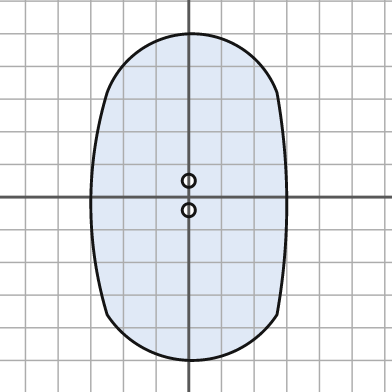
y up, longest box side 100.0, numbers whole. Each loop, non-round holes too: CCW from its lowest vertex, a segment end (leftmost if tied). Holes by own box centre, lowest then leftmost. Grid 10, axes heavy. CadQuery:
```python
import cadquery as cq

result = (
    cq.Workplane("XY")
    .moveTo(-25.0, -36.0)
    .threePointArc((1.0, -50.0), (27.0, -36.0))
    .threePointArc((30.0, -2.0), (27.0, 32.0))
    .threePointArc((1.0, 50.0), (-25.0, 32.0))
    .threePointArc((-30.0, -2.0), (-25.0, -36.0))
    .close()
    .moveTo(0.0, -4.0)
    .circle(2.0)
    .moveTo(0.0, 5.0)
    .circle(2.0)
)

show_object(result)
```